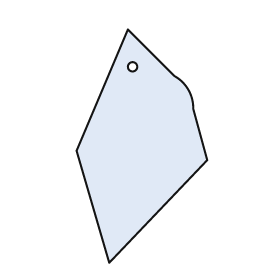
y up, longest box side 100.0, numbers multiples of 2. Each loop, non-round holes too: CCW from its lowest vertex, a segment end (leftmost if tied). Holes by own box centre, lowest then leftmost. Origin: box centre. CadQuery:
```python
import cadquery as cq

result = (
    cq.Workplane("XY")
    .moveTo(-14.0, -50.0)
    .lineTo(28.0, -6.0)
    .lineTo(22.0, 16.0)
    .threePointArc((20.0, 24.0), (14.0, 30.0))
    .lineTo(-6.0, 50.0)
    .lineTo(-28.0, -2.0)
    .close()
    .moveTo(-4.0, 34.0)
    .circle(2.0)
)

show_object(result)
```